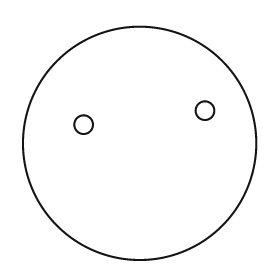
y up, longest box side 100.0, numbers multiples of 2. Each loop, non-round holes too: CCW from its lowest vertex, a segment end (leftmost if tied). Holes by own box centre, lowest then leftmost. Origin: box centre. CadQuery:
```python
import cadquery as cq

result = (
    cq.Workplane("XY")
    .moveTo(0.0, 0.0)
    .circle(50.0)
    .moveTo(-24.0, 8.0)
    .circle(4.0)
    .moveTo(28.0, 14.0)
    .circle(4.0)
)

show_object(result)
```